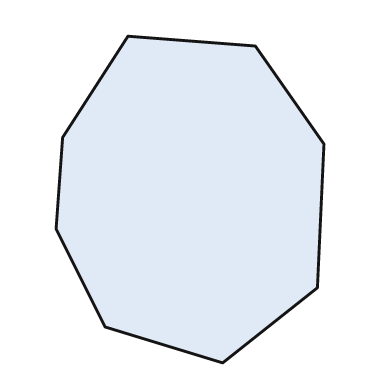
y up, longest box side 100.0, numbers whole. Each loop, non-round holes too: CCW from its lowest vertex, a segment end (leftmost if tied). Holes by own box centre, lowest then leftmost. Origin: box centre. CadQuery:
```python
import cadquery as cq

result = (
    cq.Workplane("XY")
    .moveTo(10.0, -50.0)
    .lineTo(39.0, -27.0)
    .lineTo(41.0, 17.0)
    .lineTo(20.0, 47.0)
    .lineTo(-19.0, 50.0)
    .lineTo(-39.0, 19.0)
    .lineTo(-41.0, -9.0)
    .lineTo(-26.0, -39.0)
    .close()
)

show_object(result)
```